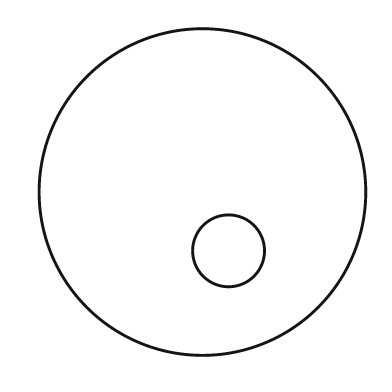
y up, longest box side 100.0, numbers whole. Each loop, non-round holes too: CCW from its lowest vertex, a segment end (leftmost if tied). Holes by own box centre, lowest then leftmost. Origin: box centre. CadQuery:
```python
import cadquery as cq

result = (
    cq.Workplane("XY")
    .moveTo(0.0, 0.0)
    .circle(50.0)
    .moveTo(8.0, -18.0)
    .circle(11.0)
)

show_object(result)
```